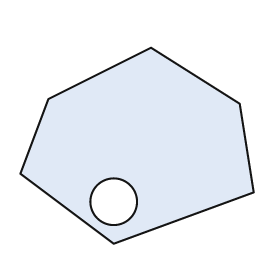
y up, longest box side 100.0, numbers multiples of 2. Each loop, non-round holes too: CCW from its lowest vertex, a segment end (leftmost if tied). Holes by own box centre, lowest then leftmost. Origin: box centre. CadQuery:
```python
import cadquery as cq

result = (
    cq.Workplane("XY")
    .moveTo(-10.0, -42.0)
    .lineTo(50.0, -20.0)
    .lineTo(44.0, 18.0)
    .lineTo(6.0, 42.0)
    .lineTo(-38.0, 20.0)
    .lineTo(-50.0, -12.0)
    .close()
    .moveTo(-10.0, -24.0)
    .circle(10.0)
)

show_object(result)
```